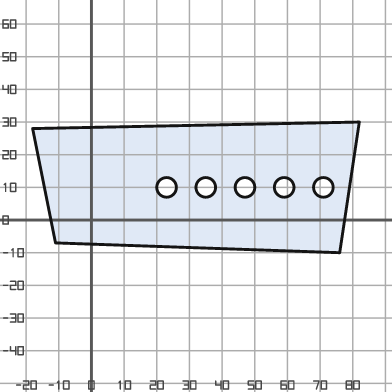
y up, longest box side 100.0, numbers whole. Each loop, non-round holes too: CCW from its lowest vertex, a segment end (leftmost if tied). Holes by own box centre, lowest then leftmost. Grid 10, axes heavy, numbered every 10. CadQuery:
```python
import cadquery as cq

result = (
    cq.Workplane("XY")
    .moveTo(76.0, -10.0)
    .lineTo(82.0, 30.0)
    .lineTo(-18.0, 28.0)
    .lineTo(-11.0, -7.0)
    .close()
    .moveTo(23.0, 10.0)
    .circle(3.0)
    .moveTo(35.0, 10.0)
    .circle(3.0)
    .moveTo(47.0, 10.0)
    .circle(3.0)
    .moveTo(59.0, 10.0)
    .circle(3.0)
    .moveTo(71.0, 10.0)
    .circle(3.0)
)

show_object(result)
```